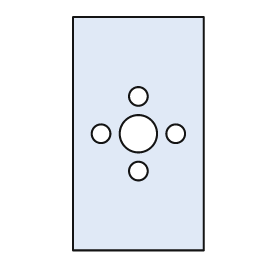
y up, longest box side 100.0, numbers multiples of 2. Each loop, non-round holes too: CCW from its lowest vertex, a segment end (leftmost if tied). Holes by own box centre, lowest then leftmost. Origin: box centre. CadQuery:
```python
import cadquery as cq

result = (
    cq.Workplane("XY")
    .moveTo(-28.0, -50.0)
    .lineTo(28.0, -50.0)
    .lineTo(28.0, 50.0)
    .lineTo(-28.0, 50.0)
    .close()
    .moveTo(0.0, -16.0)
    .circle(4.0)
    .moveTo(-16.0, 0.0)
    .circle(4.0)
    .moveTo(0.0, 0.0)
    .circle(8.0)
    .moveTo(16.0, 0.0)
    .circle(4.0)
    .moveTo(0.0, 16.0)
    .circle(4.0)
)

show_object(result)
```